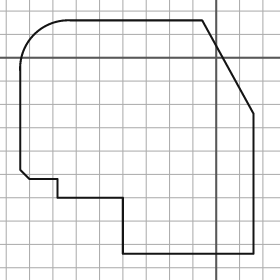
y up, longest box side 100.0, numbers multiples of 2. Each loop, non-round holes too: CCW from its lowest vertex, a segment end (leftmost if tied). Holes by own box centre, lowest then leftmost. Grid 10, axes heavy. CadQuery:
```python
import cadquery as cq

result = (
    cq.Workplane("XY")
    .moveTo(-40.0, -84.0)
    .lineTo(16.0, -84.0)
    .lineTo(16.0, -24.0)
    .lineTo(-6.0, 16.0)
    .lineTo(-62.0, 16.0)
    .threePointArc((-78.0, 10.0), (-84.0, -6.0))
    .lineTo(-84.0, -48.0)
    .lineTo(-80.0, -52.0)
    .lineTo(-68.0, -52.0)
    .lineTo(-68.0, -60.0)
    .lineTo(-40.0, -60.0)
    .close()
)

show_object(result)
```